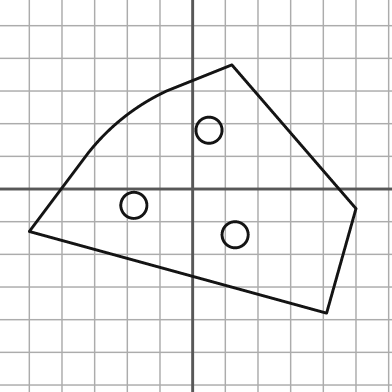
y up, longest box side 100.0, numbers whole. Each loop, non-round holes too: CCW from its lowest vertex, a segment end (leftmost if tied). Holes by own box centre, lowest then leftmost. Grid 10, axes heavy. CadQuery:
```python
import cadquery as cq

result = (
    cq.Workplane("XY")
    .moveTo(41.0, -38.0)
    .lineTo(50.0, -6.0)
    .lineTo(12.0, 38.0)
    .lineTo(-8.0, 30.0)
    .threePointArc((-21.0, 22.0), (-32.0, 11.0))
    .lineTo(-50.0, -13.0)
    .close()
    .moveTo(13.0, -14.0)
    .circle(4.0)
    .moveTo(-18.0, -5.0)
    .circle(4.0)
    .moveTo(5.0, 18.0)
    .circle(4.0)
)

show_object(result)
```